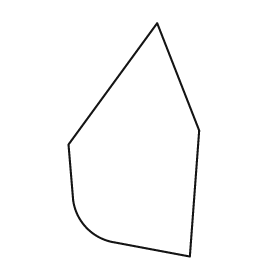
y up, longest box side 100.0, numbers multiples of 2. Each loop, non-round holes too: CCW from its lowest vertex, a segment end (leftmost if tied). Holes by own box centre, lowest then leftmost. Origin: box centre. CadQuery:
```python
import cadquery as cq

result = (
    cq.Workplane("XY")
    .moveTo(24.0, -50.0)
    .lineTo(28.0, 4.0)
    .lineTo(10.0, 50.0)
    .lineTo(-28.0, -2.0)
    .lineTo(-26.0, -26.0)
    .threePointArc((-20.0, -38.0), (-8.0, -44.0))
    .close()
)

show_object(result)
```